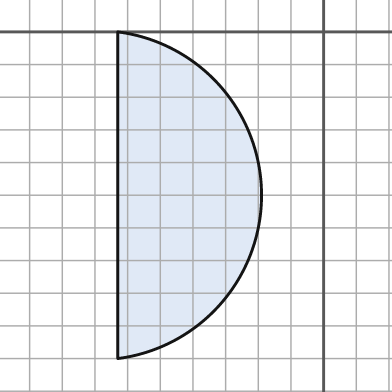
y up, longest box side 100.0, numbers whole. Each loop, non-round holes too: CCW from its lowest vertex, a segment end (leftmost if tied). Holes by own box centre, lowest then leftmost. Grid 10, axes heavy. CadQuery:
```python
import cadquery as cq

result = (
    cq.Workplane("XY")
    .moveTo(-63.0, -100.0)
    .threePointArc((-19.0, -50.0), (-63.0, 0.0))
    .close()
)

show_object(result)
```